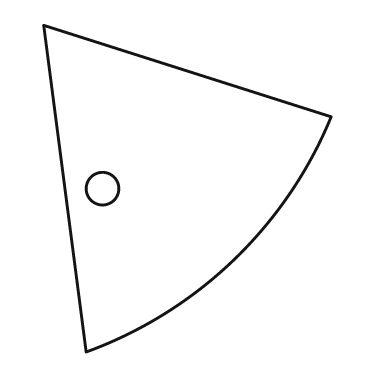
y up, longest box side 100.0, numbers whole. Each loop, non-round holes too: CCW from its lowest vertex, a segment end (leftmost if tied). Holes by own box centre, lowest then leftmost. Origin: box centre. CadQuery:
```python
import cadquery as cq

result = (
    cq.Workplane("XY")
    .moveTo(-31.0, -50.0)
    .threePointArc((14.0, -22.0), (44.0, 22.0))
    .lineTo(-44.0, 50.0)
    .close()
    .moveTo(-26.0, 0.0)
    .circle(5.0)
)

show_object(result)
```